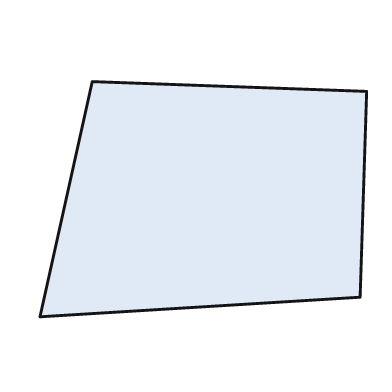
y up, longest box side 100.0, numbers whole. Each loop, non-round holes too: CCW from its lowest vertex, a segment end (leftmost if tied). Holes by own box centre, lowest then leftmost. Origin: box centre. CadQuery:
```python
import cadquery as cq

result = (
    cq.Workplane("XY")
    .moveTo(-50.0, -36.0)
    .lineTo(48.0, -30.0)
    .lineTo(50.0, 33.0)
    .lineTo(-34.0, 36.0)
    .close()
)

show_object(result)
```